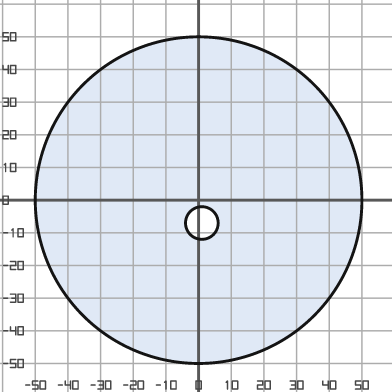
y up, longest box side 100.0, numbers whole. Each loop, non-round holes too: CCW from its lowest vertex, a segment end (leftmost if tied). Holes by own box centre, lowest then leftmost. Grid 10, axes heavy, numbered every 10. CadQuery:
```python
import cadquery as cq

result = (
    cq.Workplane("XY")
    .moveTo(0.0, 0.0)
    .circle(50.0)
    .moveTo(1.0, -7.0)
    .circle(5.0)
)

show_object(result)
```